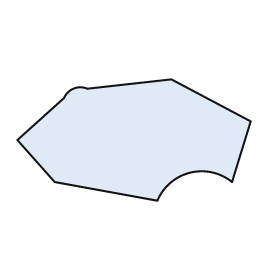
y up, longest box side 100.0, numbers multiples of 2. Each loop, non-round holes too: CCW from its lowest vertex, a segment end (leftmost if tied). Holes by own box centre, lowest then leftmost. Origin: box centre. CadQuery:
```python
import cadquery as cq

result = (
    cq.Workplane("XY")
    .moveTo(10.0, -26.0)
    .threePointArc((24.0, -14.0), (42.0, -18.0))
    .lineTo(50.0, 8.0)
    .lineTo(16.0, 26.0)
    .lineTo(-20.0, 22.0)
    .threePointArc((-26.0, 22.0), (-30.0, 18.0))
    .lineTo(-50.0, 0.0)
    .lineTo(-34.0, -18.0)
    .close()
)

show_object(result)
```